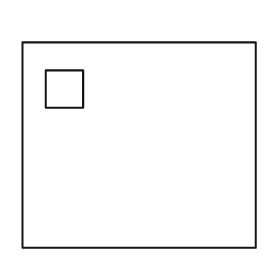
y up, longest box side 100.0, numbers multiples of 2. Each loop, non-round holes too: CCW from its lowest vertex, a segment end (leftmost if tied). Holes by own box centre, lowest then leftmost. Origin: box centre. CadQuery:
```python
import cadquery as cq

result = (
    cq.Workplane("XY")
    .moveTo(-50.0, -44.0)
    .lineTo(50.0, -44.0)
    .lineTo(50.0, 44.0)
    .lineTo(-50.0, 44.0)
    .close()
    .moveTo(-40.0, 16.0)
    .lineTo(-24.0, 16.0)
    .lineTo(-24.0, 32.0)
    .lineTo(-40.0, 32.0)
    .close()
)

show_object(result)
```